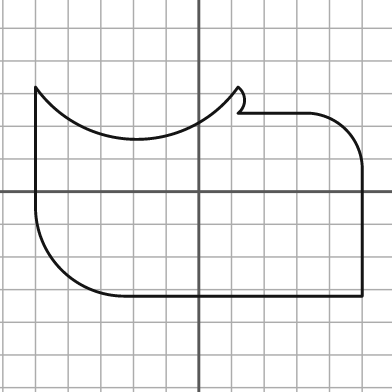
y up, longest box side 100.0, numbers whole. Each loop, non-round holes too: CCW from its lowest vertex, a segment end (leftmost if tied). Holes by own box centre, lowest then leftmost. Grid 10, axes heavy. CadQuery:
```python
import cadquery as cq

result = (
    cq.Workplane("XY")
    .moveTo(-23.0, -32.0)
    .lineTo(50.0, -32.0)
    .lineTo(50.0, 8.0)
    .threePointArc((45.0, 19.0), (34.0, 24.0))
    .lineTo(12.0, 24.0)
    .threePointArc((14.0, 28.0), (12.0, 32.0))
    .threePointArc((-19.0, 16.0), (-50.0, 32.0))
    .lineTo(-50.0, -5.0)
    .threePointArc((-42.0, -24.0), (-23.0, -32.0))
    .close()
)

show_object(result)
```